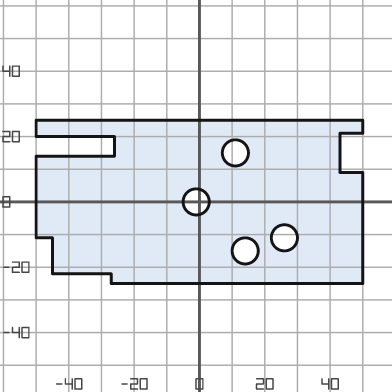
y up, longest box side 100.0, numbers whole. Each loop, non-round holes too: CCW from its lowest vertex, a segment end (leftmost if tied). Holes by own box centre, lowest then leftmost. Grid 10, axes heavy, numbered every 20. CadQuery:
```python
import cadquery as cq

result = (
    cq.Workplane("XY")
    .moveTo(-27.0, -25.0)
    .lineTo(50.0, -25.0)
    .lineTo(50.0, 9.0)
    .lineTo(43.0, 9.0)
    .lineTo(43.0, 21.0)
    .lineTo(50.0, 21.0)
    .lineTo(50.0, 25.0)
    .lineTo(-50.0, 25.0)
    .lineTo(-50.0, 20.0)
    .lineTo(-26.0, 20.0)
    .lineTo(-26.0, 14.0)
    .lineTo(-50.0, 14.0)
    .lineTo(-50.0, -11.0)
    .lineTo(-45.0, -11.0)
    .lineTo(-45.0, -22.0)
    .lineTo(-27.0, -22.0)
    .close()
    .moveTo(14.0, -15.0)
    .circle(4.0)
    .moveTo(26.0, -11.0)
    .circle(4.0)
    .moveTo(-1.0, 0.0)
    .circle(4.0)
    .moveTo(11.0, 15.0)
    .circle(4.0)
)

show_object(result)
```